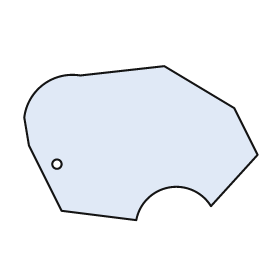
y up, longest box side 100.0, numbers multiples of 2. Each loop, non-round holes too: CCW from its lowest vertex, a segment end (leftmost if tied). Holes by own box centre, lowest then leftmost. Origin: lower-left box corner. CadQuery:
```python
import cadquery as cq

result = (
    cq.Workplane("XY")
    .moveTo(48.0, 0.0)
    .threePointArc((62.0, 14.0), (80.0, 6.0))
    .lineTo(100.0, 28.0)
    .lineTo(90.0, 48.0)
    .lineTo(60.0, 66.0)
    .lineTo(24.0, 62.0)
    .threePointArc((8.0, 58.0), (0.0, 44.0))
    .lineTo(2.0, 32.0)
    .lineTo(16.0, 4.0)
    .close()
    .moveTo(14.0, 24.0)
    .circle(2.0)
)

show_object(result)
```